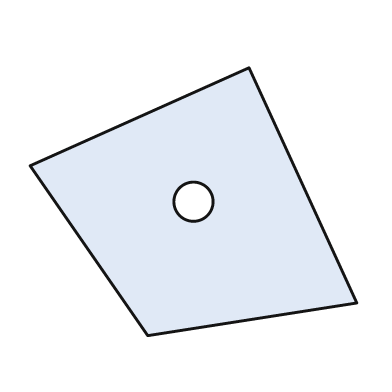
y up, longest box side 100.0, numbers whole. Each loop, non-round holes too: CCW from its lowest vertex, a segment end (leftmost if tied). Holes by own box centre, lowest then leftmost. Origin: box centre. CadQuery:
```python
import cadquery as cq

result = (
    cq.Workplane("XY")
    .moveTo(-14.0, -41.0)
    .lineTo(50.0, -31.0)
    .lineTo(17.0, 41.0)
    .lineTo(-50.0, 11.0)
    .close()
    .moveTo(0.0, 0.0)
    .circle(6.0)
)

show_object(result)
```